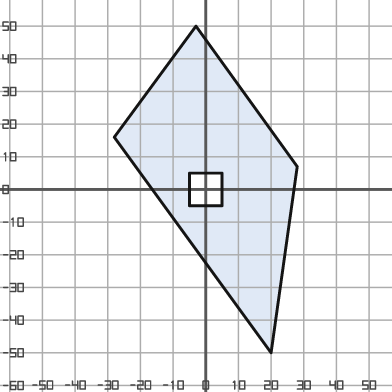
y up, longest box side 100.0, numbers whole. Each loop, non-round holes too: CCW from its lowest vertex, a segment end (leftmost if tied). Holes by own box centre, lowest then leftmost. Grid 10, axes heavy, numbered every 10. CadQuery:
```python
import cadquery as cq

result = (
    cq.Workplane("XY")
    .moveTo(20.0, -50.0)
    .lineTo(28.0, 7.0)
    .lineTo(-3.0, 50.0)
    .lineTo(-28.0, 16.0)
    .close()
    .moveTo(-5.0, -5.0)
    .lineTo(5.0, -5.0)
    .lineTo(5.0, 5.0)
    .lineTo(-5.0, 5.0)
    .close()
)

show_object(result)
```